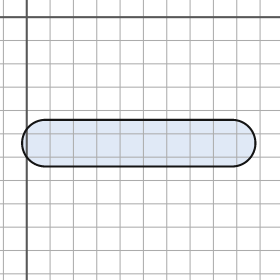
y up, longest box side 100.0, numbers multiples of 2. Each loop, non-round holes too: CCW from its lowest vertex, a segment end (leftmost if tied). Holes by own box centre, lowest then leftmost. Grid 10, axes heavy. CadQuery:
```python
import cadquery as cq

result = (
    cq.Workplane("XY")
    .moveTo(8.0, -64.0)
    .lineTo(88.0, -64.0)
    .threePointArc((98.0, -54.0), (88.0, -44.0))
    .lineTo(8.0, -44.0)
    .threePointArc((-2.0, -54.0), (8.0, -64.0))
    .close()
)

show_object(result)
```